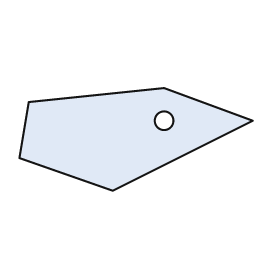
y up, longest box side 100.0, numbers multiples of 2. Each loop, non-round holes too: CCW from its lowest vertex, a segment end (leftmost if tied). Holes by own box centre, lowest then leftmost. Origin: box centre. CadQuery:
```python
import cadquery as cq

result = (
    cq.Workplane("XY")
    .moveTo(-10.0, -22.0)
    .lineTo(50.0, 8.0)
    .lineTo(12.0, 22.0)
    .lineTo(-46.0, 16.0)
    .lineTo(-50.0, -8.0)
    .close()
    .moveTo(12.0, 8.0)
    .circle(4.0)
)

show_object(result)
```